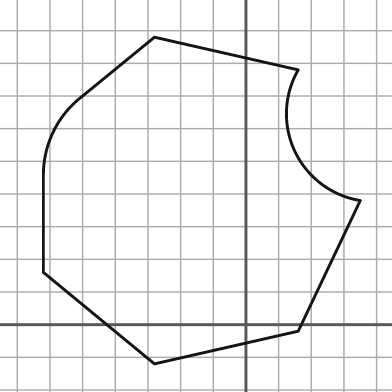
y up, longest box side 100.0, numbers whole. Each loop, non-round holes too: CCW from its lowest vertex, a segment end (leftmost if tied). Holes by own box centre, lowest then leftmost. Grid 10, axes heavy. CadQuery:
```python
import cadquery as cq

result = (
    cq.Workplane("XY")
    .moveTo(-28.0, -12.0)
    .lineTo(16.0, -2.0)
    .lineTo(35.0, 38.0)
    .threePointArc((15.0, 53.0), (16.0, 78.0))
    .lineTo(-28.0, 88.0)
    .lineTo(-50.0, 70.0)
    .threePointArc((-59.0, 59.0), (-62.0, 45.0))
    .lineTo(-62.0, 16.0)
    .close()
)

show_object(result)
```